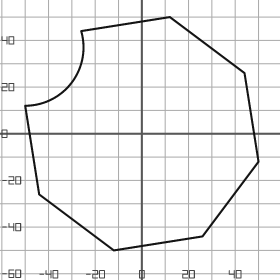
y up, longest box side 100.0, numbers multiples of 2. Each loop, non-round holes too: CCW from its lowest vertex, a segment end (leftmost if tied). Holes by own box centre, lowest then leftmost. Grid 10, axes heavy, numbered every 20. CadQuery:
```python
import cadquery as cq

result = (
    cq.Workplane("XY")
    .moveTo(-12.0, -50.0)
    .lineTo(26.0, -44.0)
    .lineTo(50.0, -12.0)
    .lineTo(44.0, 26.0)
    .lineTo(12.0, 50.0)
    .lineTo(-26.0, 44.0)
    .threePointArc((-30.0, 22.0), (-50.0, 12.0))
    .lineTo(-44.0, -26.0)
    .close()
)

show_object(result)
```